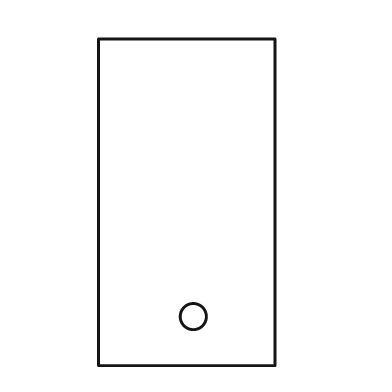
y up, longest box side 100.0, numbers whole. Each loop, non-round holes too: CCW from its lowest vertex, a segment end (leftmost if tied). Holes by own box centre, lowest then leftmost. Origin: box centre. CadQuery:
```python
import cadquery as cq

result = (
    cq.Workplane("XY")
    .moveTo(-27.0, -50.0)
    .lineTo(27.0, -50.0)
    .lineTo(27.0, 50.0)
    .lineTo(-27.0, 50.0)
    .close()
    .moveTo(2.0, -35.0)
    .circle(4.0)
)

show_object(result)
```